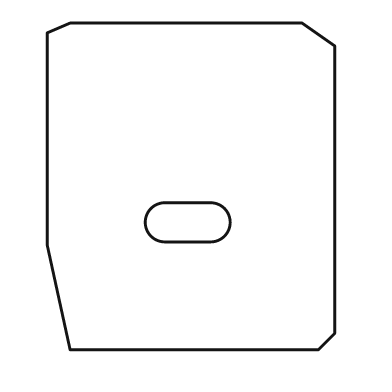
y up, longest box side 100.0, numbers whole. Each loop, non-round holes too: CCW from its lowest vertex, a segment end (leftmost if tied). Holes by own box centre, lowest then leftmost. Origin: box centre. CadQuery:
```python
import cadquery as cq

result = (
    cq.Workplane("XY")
    .moveTo(-37.0, -50.0)
    .lineTo(39.0, -50.0)
    .lineTo(44.0, -45.0)
    .lineTo(44.0, 43.0)
    .lineTo(34.0, 50.0)
    .lineTo(-37.0, 50.0)
    .lineTo(-44.0, 47.0)
    .lineTo(-44.0, -18.0)
    .close()
    .moveTo(-8.0, -17.0)
    .lineTo(6.0, -17.0)
    .threePointArc((12.0, -11.0), (6.0, -5.0))
    .lineTo(-8.0, -5.0)
    .threePointArc((-14.0, -11.0), (-8.0, -17.0))
    .close()
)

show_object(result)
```